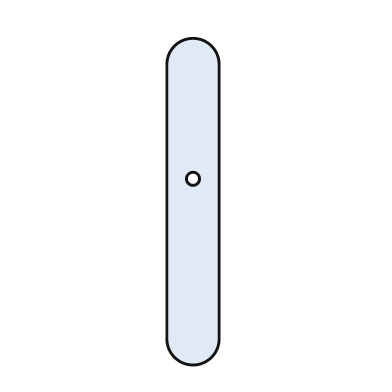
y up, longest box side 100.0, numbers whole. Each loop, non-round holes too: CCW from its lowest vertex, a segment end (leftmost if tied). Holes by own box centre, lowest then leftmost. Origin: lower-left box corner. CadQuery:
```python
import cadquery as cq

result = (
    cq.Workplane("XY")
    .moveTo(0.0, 8.0)
    .threePointArc((8.0, 0.0), (16.0, 8.0))
    .lineTo(16.0, 92.0)
    .threePointArc((8.0, 100.0), (0.0, 92.0))
    .close()
    .moveTo(8.0, 57.0)
    .circle(2.0)
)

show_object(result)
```